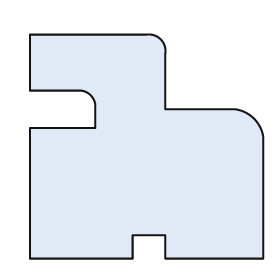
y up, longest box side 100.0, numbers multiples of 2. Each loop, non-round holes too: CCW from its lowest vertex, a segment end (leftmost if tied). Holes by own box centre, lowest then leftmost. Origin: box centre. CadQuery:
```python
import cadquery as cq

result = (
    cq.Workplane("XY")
    .moveTo(-50.0, -48.0)
    .lineTo(-6.0, -48.0)
    .lineTo(-6.0, -38.0)
    .lineTo(8.0, -38.0)
    .lineTo(8.0, -48.0)
    .lineTo(50.0, -48.0)
    .lineTo(50.0, 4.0)
    .threePointArc((46.0, 12.0), (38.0, 16.0))
    .lineTo(8.0, 16.0)
    .lineTo(8.0, 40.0)
    .threePointArc((6.0, 46.0), (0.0, 48.0))
    .lineTo(-50.0, 48.0)
    .lineTo(-50.0, 24.0)
    .lineTo(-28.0, 24.0)
    .threePointArc((-24.0, 22.0), (-22.0, 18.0))
    .lineTo(-22.0, 8.0)
    .lineTo(-50.0, 8.0)
    .close()
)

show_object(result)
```